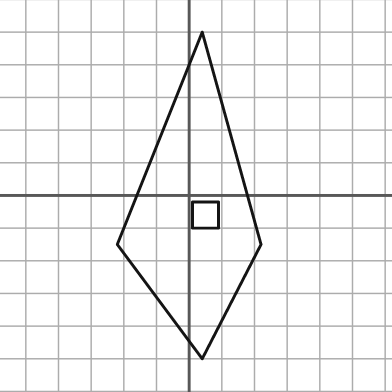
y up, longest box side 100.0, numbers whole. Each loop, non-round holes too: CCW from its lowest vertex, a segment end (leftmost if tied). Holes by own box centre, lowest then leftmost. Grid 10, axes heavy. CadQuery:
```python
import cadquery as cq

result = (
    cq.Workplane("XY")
    .moveTo(4.0, -50.0)
    .lineTo(22.0, -15.0)
    .lineTo(4.0, 50.0)
    .lineTo(-22.0, -15.0)
    .close()
    .moveTo(1.0, -10.0)
    .lineTo(9.0, -10.0)
    .lineTo(9.0, -2.0)
    .lineTo(1.0, -2.0)
    .close()
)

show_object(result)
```